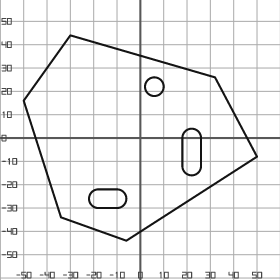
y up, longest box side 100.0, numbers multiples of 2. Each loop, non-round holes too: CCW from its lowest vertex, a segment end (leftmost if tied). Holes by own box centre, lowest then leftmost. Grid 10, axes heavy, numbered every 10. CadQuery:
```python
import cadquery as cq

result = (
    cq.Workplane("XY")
    .moveTo(-6.0, -44.0)
    .lineTo(50.0, -8.0)
    .lineTo(32.0, 26.0)
    .lineTo(-30.0, 44.0)
    .lineTo(-50.0, 16.0)
    .lineTo(-34.0, -34.0)
    .close()
    .moveTo(-18.0, -30.0)
    .lineTo(-10.0, -30.0)
    .threePointArc((-6.0, -26.0), (-10.0, -22.0))
    .lineTo(-18.0, -22.0)
    .threePointArc((-22.0, -26.0), (-18.0, -30.0))
    .close()
    .moveTo(18.0, -12.0)
    .threePointArc((22.0, -16.0), (26.0, -12.0))
    .lineTo(26.0, 0.0)
    .threePointArc((22.0, 4.0), (18.0, 0.0))
    .close()
    .moveTo(6.0, 22.0)
    .circle(4.0)
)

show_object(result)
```